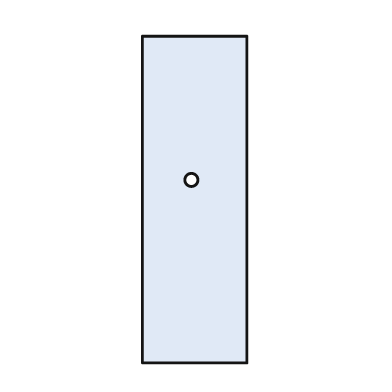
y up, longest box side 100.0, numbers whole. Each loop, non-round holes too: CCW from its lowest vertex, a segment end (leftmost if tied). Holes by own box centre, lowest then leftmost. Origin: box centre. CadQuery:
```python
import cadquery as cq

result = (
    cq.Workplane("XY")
    .moveTo(-16.0, -50.0)
    .lineTo(16.0, -50.0)
    .lineTo(16.0, 50.0)
    .lineTo(-16.0, 50.0)
    .close()
    .moveTo(-1.0, 6.0)
    .circle(2.0)
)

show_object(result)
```